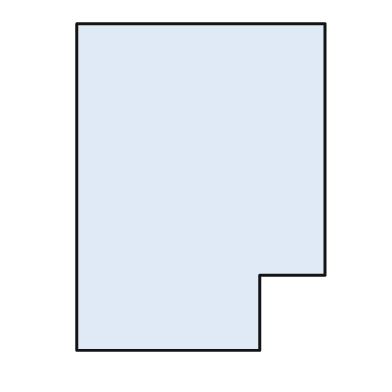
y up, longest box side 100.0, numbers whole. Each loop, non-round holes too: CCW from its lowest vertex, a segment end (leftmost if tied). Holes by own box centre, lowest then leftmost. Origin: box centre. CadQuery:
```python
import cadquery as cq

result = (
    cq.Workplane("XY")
    .moveTo(-38.0, -50.0)
    .lineTo(18.0, -50.0)
    .lineTo(18.0, -27.0)
    .lineTo(38.0, -27.0)
    .lineTo(38.0, 50.0)
    .lineTo(-38.0, 50.0)
    .close()
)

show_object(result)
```